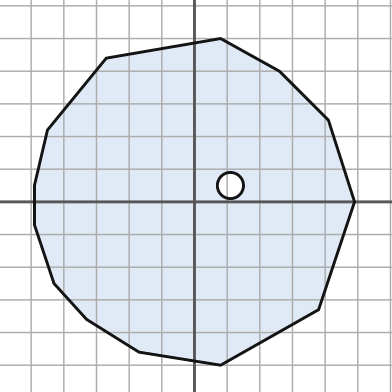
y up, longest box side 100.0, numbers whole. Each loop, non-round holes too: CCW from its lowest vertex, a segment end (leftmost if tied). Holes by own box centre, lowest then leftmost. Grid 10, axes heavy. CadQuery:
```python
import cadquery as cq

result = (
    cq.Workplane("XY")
    .moveTo(8.0, -50.0)
    .lineTo(38.0, -33.0)
    .lineTo(49.0, 0.0)
    .lineTo(41.0, 25.0)
    .lineTo(26.0, 40.0)
    .lineTo(8.0, 50.0)
    .lineTo(-27.0, 44.0)
    .lineTo(-45.0, 22.0)
    .lineTo(-49.0, 5.0)
    .lineTo(-49.0, -7.0)
    .lineTo(-43.0, -25.0)
    .lineTo(-33.0, -36.0)
    .lineTo(-17.0, -46.0)
    .close()
    .moveTo(11.0, 5.0)
    .circle(4.0)
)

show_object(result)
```